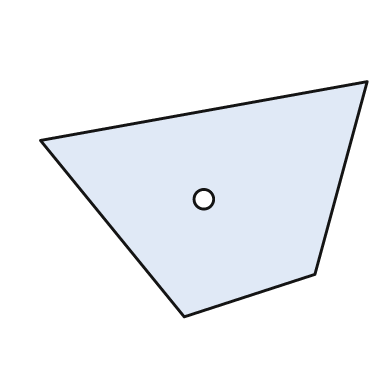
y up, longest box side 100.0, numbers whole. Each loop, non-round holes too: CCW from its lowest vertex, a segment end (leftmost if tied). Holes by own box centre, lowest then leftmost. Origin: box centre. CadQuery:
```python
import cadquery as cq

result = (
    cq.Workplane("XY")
    .moveTo(-6.0, -36.0)
    .lineTo(34.0, -23.0)
    .lineTo(50.0, 36.0)
    .lineTo(-50.0, 18.0)
    .close()
    .moveTo(0.0, 0.0)
    .circle(3.0)
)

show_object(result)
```